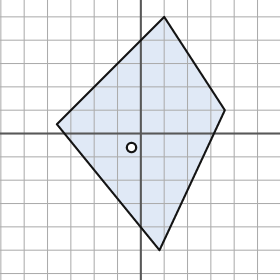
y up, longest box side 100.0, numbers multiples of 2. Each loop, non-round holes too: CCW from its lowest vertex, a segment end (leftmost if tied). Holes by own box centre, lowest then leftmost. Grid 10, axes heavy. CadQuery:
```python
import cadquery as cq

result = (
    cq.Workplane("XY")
    .moveTo(8.0, -50.0)
    .lineTo(36.0, 10.0)
    .lineTo(10.0, 50.0)
    .lineTo(-36.0, 4.0)
    .close()
    .moveTo(-4.0, -6.0)
    .circle(2.0)
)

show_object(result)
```